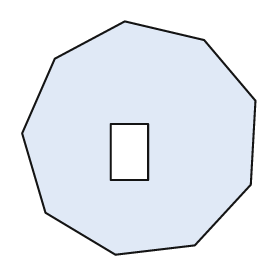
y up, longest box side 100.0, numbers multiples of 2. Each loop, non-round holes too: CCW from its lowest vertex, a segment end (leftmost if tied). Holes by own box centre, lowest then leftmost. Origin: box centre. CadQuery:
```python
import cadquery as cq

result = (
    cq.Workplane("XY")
    .moveTo(-10.0, -50.0)
    .lineTo(24.0, -46.0)
    .lineTo(48.0, -20.0)
    .lineTo(50.0, 16.0)
    .lineTo(28.0, 42.0)
    .lineTo(-6.0, 50.0)
    .lineTo(-36.0, 34.0)
    .lineTo(-50.0, 2.0)
    .lineTo(-40.0, -32.0)
    .close()
    .moveTo(-12.0, -18.0)
    .lineTo(4.0, -18.0)
    .lineTo(4.0, 6.0)
    .lineTo(-12.0, 6.0)
    .close()
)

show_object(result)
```